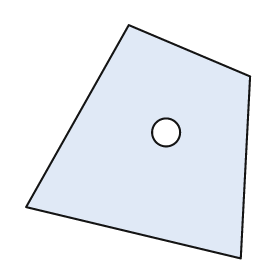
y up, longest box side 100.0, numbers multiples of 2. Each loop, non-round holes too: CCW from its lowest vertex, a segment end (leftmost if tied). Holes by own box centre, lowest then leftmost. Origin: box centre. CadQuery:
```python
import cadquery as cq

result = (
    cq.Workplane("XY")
    .moveTo(44.0, -50.0)
    .lineTo(48.0, 28.0)
    .lineTo(-4.0, 50.0)
    .lineTo(-48.0, -28.0)
    .close()
    .moveTo(12.0, 4.0)
    .circle(6.0)
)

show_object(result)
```